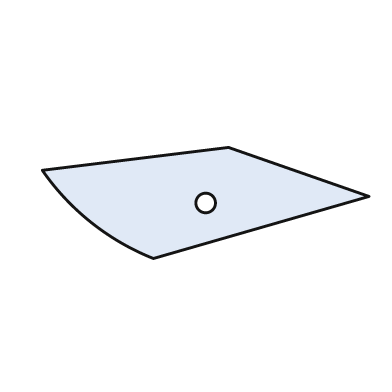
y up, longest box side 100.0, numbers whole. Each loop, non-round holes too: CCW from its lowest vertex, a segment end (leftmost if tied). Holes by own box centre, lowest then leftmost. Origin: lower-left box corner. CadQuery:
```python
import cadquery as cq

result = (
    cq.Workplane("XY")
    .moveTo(34.0, 0.0)
    .lineTo(100.0, 19.0)
    .lineTo(57.0, 34.0)
    .lineTo(0.0, 27.0)
    .threePointArc((15.0, 11.0), (34.0, 0.0))
    .close()
    .moveTo(50.0, 17.0)
    .circle(3.0)
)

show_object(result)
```